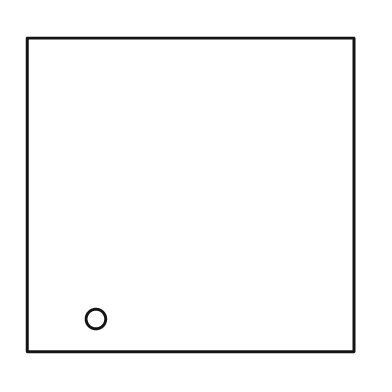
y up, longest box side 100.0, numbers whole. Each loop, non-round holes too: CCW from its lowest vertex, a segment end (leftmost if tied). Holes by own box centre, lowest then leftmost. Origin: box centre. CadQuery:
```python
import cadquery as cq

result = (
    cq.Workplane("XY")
    .moveTo(-50.0, -48.0)
    .lineTo(50.0, -48.0)
    .lineTo(50.0, 48.0)
    .lineTo(-50.0, 48.0)
    .close()
    .moveTo(-29.0, -38.0)
    .circle(3.0)
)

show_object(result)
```